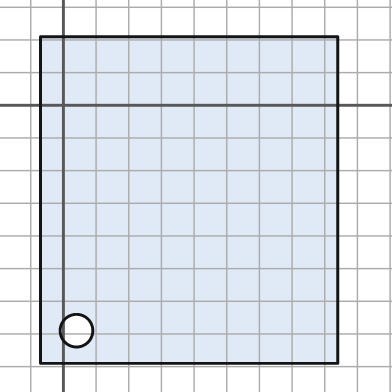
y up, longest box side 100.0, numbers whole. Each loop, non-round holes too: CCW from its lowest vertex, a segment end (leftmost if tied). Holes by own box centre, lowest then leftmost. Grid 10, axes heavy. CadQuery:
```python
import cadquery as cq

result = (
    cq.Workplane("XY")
    .moveTo(-7.0, -79.0)
    .lineTo(84.0, -79.0)
    .lineTo(84.0, 21.0)
    .lineTo(-7.0, 21.0)
    .close()
    .moveTo(4.0, -69.0)
    .circle(5.0)
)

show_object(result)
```